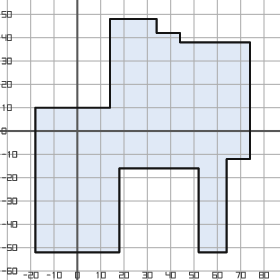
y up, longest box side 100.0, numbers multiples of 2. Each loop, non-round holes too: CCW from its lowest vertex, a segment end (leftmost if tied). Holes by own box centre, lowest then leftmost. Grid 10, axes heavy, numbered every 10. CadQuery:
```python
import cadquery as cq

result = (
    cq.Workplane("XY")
    .moveTo(-18.0, -52.0)
    .lineTo(18.0, -52.0)
    .lineTo(18.0, -16.0)
    .lineTo(52.0, -16.0)
    .lineTo(52.0, -52.0)
    .lineTo(64.0, -52.0)
    .lineTo(64.0, -12.0)
    .lineTo(74.0, -12.0)
    .lineTo(74.0, 38.0)
    .lineTo(44.0, 38.0)
    .lineTo(44.0, 42.0)
    .lineTo(34.0, 42.0)
    .lineTo(34.0, 48.0)
    .lineTo(14.0, 48.0)
    .lineTo(14.0, 10.0)
    .lineTo(-18.0, 10.0)
    .close()
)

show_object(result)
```